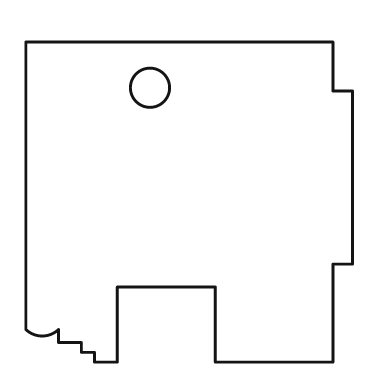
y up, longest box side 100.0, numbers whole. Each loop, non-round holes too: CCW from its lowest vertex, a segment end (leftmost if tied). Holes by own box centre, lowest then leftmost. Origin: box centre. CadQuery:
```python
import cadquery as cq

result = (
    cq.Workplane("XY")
    .moveTo(-29.0, -49.0)
    .lineTo(-22.0, -49.0)
    .lineTo(-22.0, -26.0)
    .lineTo(8.0, -26.0)
    .lineTo(8.0, -49.0)
    .lineTo(44.0, -49.0)
    .lineTo(44.0, -19.0)
    .lineTo(50.0, -19.0)
    .lineTo(50.0, 34.0)
    .lineTo(44.0, 34.0)
    .lineTo(44.0, 49.0)
    .lineTo(-50.0, 49.0)
    .lineTo(-50.0, -39.0)
    .threePointArc((-45.0, -41.0), (-40.0, -39.0))
    .lineTo(-40.0, -43.0)
    .lineTo(-33.0, -43.0)
    .lineTo(-33.0, -46.0)
    .lineTo(-29.0, -46.0)
    .close()
    .moveTo(-12.0, 35.0)
    .circle(6.0)
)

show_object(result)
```